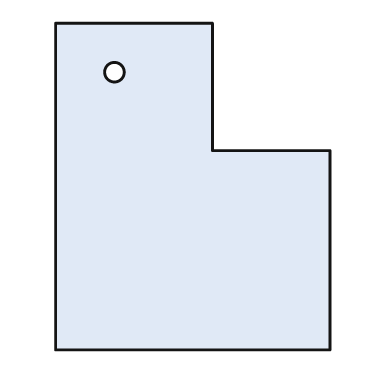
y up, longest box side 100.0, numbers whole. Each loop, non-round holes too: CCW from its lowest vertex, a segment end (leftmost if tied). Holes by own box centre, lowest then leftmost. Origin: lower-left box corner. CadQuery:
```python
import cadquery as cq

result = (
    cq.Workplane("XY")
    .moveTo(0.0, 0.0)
    .lineTo(84.0, 0.0)
    .lineTo(84.0, 61.0)
    .lineTo(48.0, 61.0)
    .lineTo(48.0, 100.0)
    .lineTo(0.0, 100.0)
    .close()
    .moveTo(18.0, 85.0)
    .circle(3.0)
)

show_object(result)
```